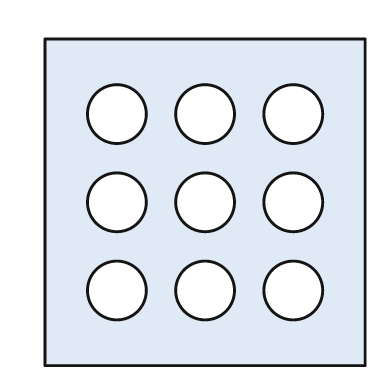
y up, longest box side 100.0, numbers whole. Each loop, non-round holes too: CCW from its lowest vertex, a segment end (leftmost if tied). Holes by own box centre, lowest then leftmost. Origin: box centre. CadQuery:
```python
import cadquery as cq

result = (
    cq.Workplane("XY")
    .moveTo(-49.0, -50.0)
    .lineTo(49.0, -50.0)
    .lineTo(49.0, 50.0)
    .lineTo(-49.0, 50.0)
    .close()
    .moveTo(-27.0, -27.0)
    .circle(9.0)
    .moveTo(0.0, -27.0)
    .circle(9.0)
    .moveTo(27.0, -27.0)
    .circle(9.0)
    .moveTo(-27.0, 0.0)
    .circle(9.0)
    .moveTo(0.0, 0.0)
    .circle(9.0)
    .moveTo(27.0, 0.0)
    .circle(9.0)
    .moveTo(-27.0, 27.0)
    .circle(9.0)
    .moveTo(0.0, 27.0)
    .circle(9.0)
    .moveTo(27.0, 27.0)
    .circle(9.0)
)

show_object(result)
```